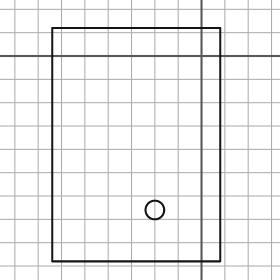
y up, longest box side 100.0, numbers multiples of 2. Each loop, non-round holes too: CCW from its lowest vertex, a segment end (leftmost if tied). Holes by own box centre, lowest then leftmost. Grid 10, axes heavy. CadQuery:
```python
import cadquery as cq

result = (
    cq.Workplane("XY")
    .moveTo(-64.0, -88.0)
    .lineTo(8.0, -88.0)
    .lineTo(8.0, 12.0)
    .lineTo(-64.0, 12.0)
    .close()
    .moveTo(-20.0, -66.0)
    .circle(4.0)
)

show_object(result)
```